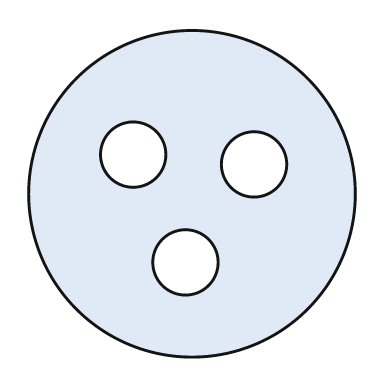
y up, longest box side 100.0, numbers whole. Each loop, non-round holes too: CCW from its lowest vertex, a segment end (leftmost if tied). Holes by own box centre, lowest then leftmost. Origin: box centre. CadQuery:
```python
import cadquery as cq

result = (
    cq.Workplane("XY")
    .moveTo(0.0, 0.0)
    .circle(50.0)
    .moveTo(-2.0, -21.0)
    .circle(10.0)
    .moveTo(19.0, 9.0)
    .circle(10.0)
    .moveTo(-18.0, 12.0)
    .circle(10.0)
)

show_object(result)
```